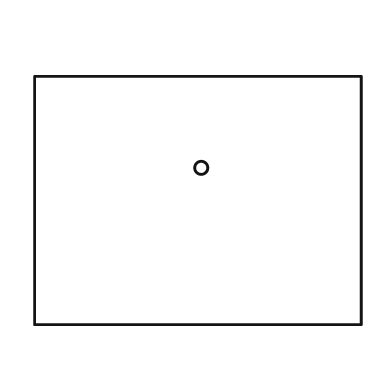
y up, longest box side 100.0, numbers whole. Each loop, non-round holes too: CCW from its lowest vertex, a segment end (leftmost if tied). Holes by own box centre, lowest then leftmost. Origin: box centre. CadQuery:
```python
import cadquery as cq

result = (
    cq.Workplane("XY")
    .moveTo(-50.0, -38.0)
    .lineTo(50.0, -38.0)
    .lineTo(50.0, 38.0)
    .lineTo(-50.0, 38.0)
    .close()
    .moveTo(1.0, 10.0)
    .circle(2.0)
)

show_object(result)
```